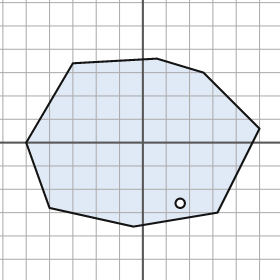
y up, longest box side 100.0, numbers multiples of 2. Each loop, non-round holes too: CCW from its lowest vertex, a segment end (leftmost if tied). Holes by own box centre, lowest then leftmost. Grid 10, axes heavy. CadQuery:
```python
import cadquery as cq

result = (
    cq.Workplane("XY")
    .moveTo(-4.0, -36.0)
    .lineTo(32.0, -30.0)
    .lineTo(50.0, 6.0)
    .lineTo(26.0, 30.0)
    .lineTo(6.0, 36.0)
    .lineTo(-30.0, 34.0)
    .lineTo(-50.0, 0.0)
    .lineTo(-40.0, -28.0)
    .close()
    .moveTo(16.0, -26.0)
    .circle(2.0)
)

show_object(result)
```